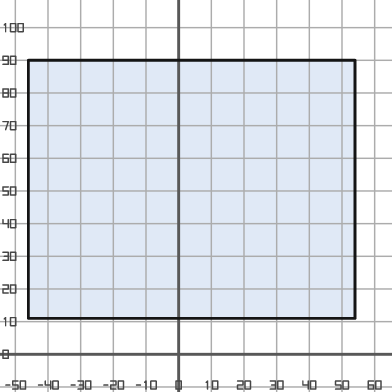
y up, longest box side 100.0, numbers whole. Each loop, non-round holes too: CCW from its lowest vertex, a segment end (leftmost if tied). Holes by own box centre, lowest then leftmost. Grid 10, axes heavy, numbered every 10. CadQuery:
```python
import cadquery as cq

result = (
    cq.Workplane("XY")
    .moveTo(-46.0, 11.0)
    .lineTo(54.0, 11.0)
    .lineTo(54.0, 90.0)
    .lineTo(-46.0, 90.0)
    .close()
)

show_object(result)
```